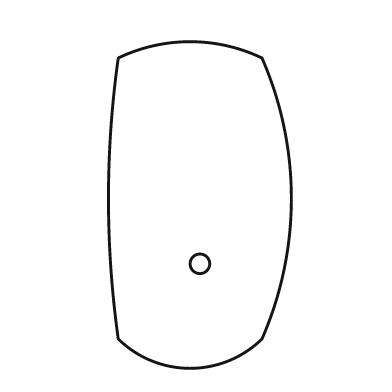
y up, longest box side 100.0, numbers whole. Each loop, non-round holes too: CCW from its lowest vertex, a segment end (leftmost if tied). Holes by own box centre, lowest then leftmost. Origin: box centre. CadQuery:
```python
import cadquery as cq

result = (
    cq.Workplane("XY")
    .moveTo(-25.0, -41.0)
    .threePointArc((-3.0, -50.0), (19.0, -41.0))
    .threePointArc((28.0, 2.0), (19.0, 45.0))
    .threePointArc((-3.0, 50.0), (-25.0, 45.0))
    .threePointArc((-28.0, 2.0), (-25.0, -41.0))
    .close()
    .moveTo(0.0, -18.0)
    .circle(3.0)
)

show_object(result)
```